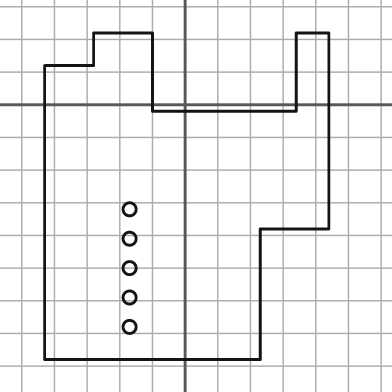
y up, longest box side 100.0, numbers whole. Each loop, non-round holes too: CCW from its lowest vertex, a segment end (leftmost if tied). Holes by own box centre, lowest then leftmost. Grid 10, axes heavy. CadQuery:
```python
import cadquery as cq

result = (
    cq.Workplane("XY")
    .moveTo(-43.0, -78.0)
    .lineTo(23.0, -78.0)
    .lineTo(23.0, -38.0)
    .lineTo(44.0, -38.0)
    .lineTo(44.0, 22.0)
    .lineTo(34.0, 22.0)
    .lineTo(34.0, -2.0)
    .lineTo(-10.0, -2.0)
    .lineTo(-10.0, 22.0)
    .lineTo(-28.0, 22.0)
    .lineTo(-28.0, 12.0)
    .lineTo(-43.0, 12.0)
    .close()
    .moveTo(-17.0, -68.0)
    .circle(2.0)
    .moveTo(-17.0, -59.0)
    .circle(2.0)
    .moveTo(-17.0, -50.0)
    .circle(2.0)
    .moveTo(-17.0, -41.0)
    .circle(2.0)
    .moveTo(-17.0, -32.0)
    .circle(2.0)
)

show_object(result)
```